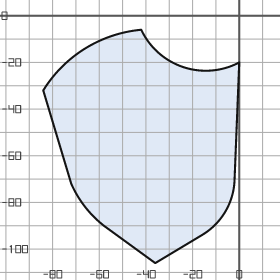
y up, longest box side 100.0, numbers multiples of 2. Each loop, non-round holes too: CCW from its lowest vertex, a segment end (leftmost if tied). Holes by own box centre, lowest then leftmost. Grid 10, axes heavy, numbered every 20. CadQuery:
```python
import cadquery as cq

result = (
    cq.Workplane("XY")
    .moveTo(-36.0, -106.0)
    .lineTo(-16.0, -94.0)
    .threePointArc((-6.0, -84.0), (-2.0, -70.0))
    .lineTo(0.0, -20.0)
    .threePointArc((-24.0, -22.0), (-42.0, -6.0))
    .threePointArc((-66.0, -14.0), (-84.0, -32.0))
    .lineTo(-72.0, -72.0)
    .threePointArc((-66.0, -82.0), (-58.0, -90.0))
    .close()
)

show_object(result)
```